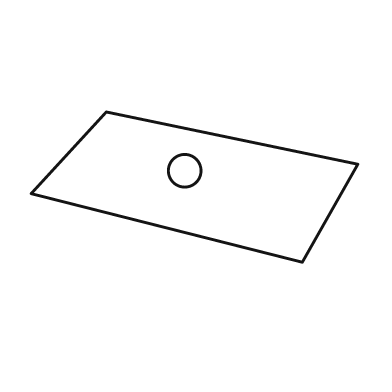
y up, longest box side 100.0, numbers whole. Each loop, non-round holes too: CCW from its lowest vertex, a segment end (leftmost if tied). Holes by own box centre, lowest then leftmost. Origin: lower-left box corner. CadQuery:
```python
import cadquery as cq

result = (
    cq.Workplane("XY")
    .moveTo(83.0, 0.0)
    .lineTo(100.0, 30.0)
    .lineTo(23.0, 46.0)
    .lineTo(0.0, 21.0)
    .close()
    .moveTo(47.0, 28.0)
    .circle(5.0)
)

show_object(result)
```